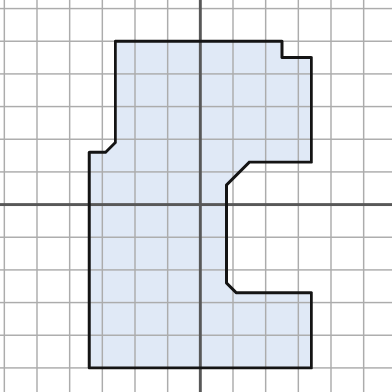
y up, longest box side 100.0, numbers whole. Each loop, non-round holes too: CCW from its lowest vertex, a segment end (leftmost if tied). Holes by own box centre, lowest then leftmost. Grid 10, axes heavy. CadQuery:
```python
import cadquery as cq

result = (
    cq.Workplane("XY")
    .moveTo(-34.0, -50.0)
    .lineTo(34.0, -50.0)
    .lineTo(34.0, -27.0)
    .lineTo(11.0, -27.0)
    .lineTo(8.0, -24.0)
    .lineTo(8.0, 6.0)
    .lineTo(15.0, 13.0)
    .lineTo(34.0, 13.0)
    .lineTo(34.0, 45.0)
    .lineTo(25.0, 45.0)
    .lineTo(25.0, 50.0)
    .lineTo(-26.0, 50.0)
    .lineTo(-26.0, 19.0)
    .lineTo(-29.0, 16.0)
    .lineTo(-34.0, 16.0)
    .close()
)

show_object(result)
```